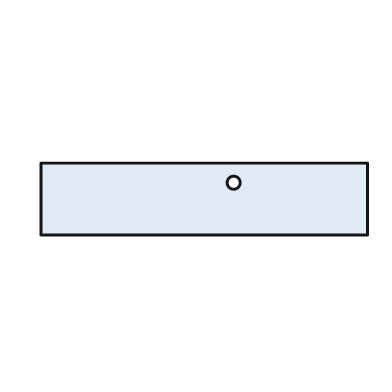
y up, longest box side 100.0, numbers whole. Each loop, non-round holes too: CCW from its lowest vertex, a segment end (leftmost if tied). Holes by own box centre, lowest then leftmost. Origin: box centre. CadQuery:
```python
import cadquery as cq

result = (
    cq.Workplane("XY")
    .moveTo(-50.0, -11.0)
    .lineTo(50.0, -11.0)
    .lineTo(50.0, 11.0)
    .lineTo(-50.0, 11.0)
    .close()
    .moveTo(9.0, 5.0)
    .circle(2.0)
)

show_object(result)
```